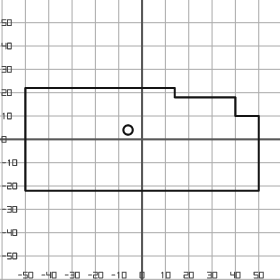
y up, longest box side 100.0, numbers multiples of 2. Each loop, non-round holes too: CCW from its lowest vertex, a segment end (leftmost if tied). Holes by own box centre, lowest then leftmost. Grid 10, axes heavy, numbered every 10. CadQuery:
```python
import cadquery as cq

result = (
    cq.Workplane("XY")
    .moveTo(-50.0, -22.0)
    .lineTo(50.0, -22.0)
    .lineTo(50.0, 10.0)
    .lineTo(40.0, 10.0)
    .lineTo(40.0, 18.0)
    .lineTo(14.0, 18.0)
    .lineTo(14.0, 22.0)
    .lineTo(-50.0, 22.0)
    .close()
    .moveTo(-6.0, 4.0)
    .circle(2.0)
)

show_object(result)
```